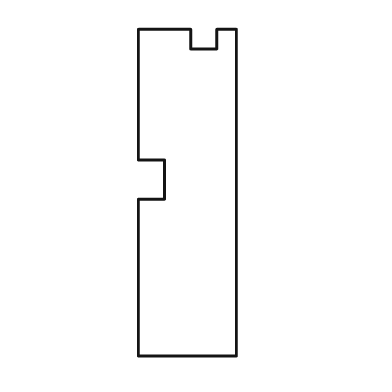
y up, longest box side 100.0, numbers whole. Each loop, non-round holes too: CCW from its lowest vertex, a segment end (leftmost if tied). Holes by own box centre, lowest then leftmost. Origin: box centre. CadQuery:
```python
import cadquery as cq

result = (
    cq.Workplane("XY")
    .moveTo(-15.0, -50.0)
    .lineTo(15.0, -50.0)
    .lineTo(15.0, 50.0)
    .lineTo(9.0, 50.0)
    .lineTo(9.0, 44.0)
    .lineTo(1.0, 44.0)
    .lineTo(1.0, 50.0)
    .lineTo(-15.0, 50.0)
    .lineTo(-15.0, 10.0)
    .lineTo(-7.0, 10.0)
    .lineTo(-7.0, -2.0)
    .lineTo(-15.0, -2.0)
    .close()
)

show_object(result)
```